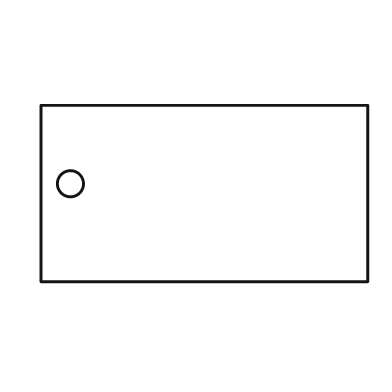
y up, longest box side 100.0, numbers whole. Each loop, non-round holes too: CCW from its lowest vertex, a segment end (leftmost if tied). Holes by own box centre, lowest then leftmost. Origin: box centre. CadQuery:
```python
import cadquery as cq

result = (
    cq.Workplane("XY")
    .moveTo(-50.0, -27.0)
    .lineTo(50.0, -27.0)
    .lineTo(50.0, 27.0)
    .lineTo(-50.0, 27.0)
    .close()
    .moveTo(-41.0, 3.0)
    .circle(4.0)
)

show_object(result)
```